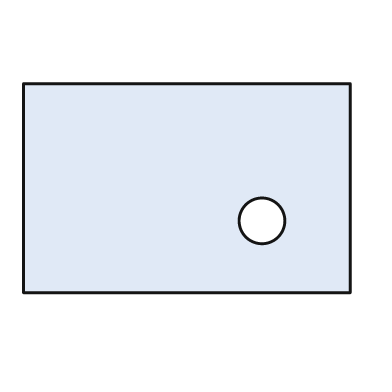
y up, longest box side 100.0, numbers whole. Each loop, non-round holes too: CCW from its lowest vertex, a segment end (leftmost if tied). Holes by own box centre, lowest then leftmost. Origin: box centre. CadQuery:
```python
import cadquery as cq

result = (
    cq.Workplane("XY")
    .moveTo(-50.0, -32.0)
    .lineTo(50.0, -32.0)
    .lineTo(50.0, 32.0)
    .lineTo(-50.0, 32.0)
    .close()
    .moveTo(23.0, -10.0)
    .circle(7.0)
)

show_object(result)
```